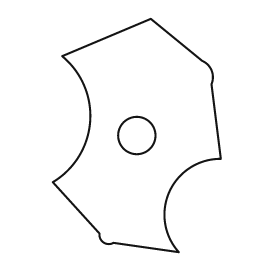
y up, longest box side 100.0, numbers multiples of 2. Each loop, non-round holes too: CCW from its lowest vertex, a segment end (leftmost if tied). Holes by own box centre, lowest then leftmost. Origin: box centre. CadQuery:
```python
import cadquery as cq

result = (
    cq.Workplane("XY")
    .moveTo(18.0, -50.0)
    .threePointArc((14.0, -24.0), (36.0, -10.0))
    .lineTo(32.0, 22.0)
    .threePointArc((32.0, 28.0), (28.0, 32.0))
    .lineTo(6.0, 50.0)
    .lineTo(-32.0, 34.0)
    .threePointArc((-20.0, 6.0), (-36.0, -20.0))
    .lineTo(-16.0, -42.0)
    .threePointArc((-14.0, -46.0), (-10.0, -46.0))
    .close()
    .moveTo(0.0, 0.0)
    .circle(8.0)
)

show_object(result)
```